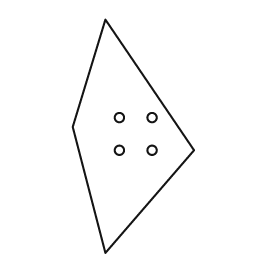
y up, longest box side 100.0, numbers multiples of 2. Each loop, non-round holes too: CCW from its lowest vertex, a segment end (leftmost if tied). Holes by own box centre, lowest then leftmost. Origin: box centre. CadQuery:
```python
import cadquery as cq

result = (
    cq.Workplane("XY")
    .moveTo(-12.0, -50.0)
    .lineTo(26.0, -6.0)
    .lineTo(-12.0, 50.0)
    .lineTo(-26.0, 4.0)
    .close()
    .moveTo(-6.0, -6.0)
    .circle(2.0)
    .moveTo(8.0, -6.0)
    .circle(2.0)
    .moveTo(-6.0, 8.0)
    .circle(2.0)
    .moveTo(8.0, 8.0)
    .circle(2.0)
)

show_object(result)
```